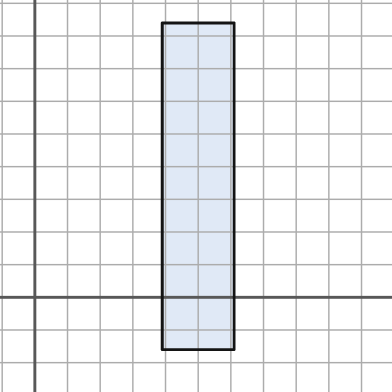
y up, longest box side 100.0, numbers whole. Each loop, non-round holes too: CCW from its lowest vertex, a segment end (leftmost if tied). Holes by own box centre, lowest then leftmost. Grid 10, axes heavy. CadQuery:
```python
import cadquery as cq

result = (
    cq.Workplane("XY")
    .moveTo(39.0, -16.0)
    .lineTo(61.0, -16.0)
    .lineTo(61.0, 84.0)
    .lineTo(39.0, 84.0)
    .close()
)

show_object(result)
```